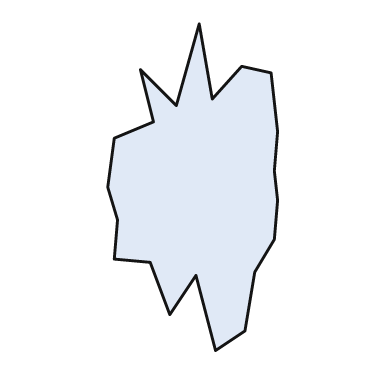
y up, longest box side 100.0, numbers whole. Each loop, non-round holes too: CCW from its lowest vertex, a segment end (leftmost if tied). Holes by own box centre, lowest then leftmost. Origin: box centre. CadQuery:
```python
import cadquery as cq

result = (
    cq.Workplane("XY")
    .moveTo(7.0, -50.0)
    .lineTo(16.0, -44.0)
    .lineTo(19.0, -26.0)
    .lineTo(25.0, -16.0)
    .lineTo(26.0, -4.0)
    .lineTo(25.0, 5.0)
    .lineTo(26.0, 17.0)
    .lineTo(24.0, 35.0)
    .lineTo(15.0, 37.0)
    .lineTo(6.0, 27.0)
    .lineTo(2.0, 50.0)
    .lineTo(-5.0, 25.0)
    .lineTo(-16.0, 36.0)
    .lineTo(-12.0, 20.0)
    .lineTo(-24.0, 15.0)
    .lineTo(-26.0, 0.0)
    .lineTo(-23.0, -10.0)
    .lineTo(-24.0, -22.0)
    .lineTo(-13.0, -23.0)
    .lineTo(-7.0, -39.0)
    .lineTo(1.0, -27.0)
    .close()
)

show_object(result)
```